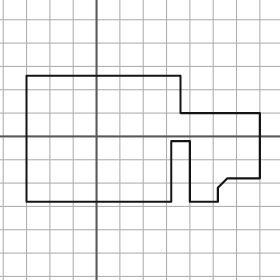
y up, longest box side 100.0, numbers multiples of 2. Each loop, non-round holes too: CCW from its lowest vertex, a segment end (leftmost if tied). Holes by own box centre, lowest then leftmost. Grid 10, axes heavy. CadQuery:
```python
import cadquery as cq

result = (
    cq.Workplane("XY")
    .moveTo(-30.0, -28.0)
    .lineTo(32.0, -28.0)
    .lineTo(32.0, -2.0)
    .lineTo(40.0, -2.0)
    .lineTo(40.0, -28.0)
    .lineTo(52.0, -28.0)
    .lineTo(52.0, -22.0)
    .lineTo(56.0, -18.0)
    .lineTo(70.0, -18.0)
    .lineTo(70.0, 10.0)
    .lineTo(36.0, 10.0)
    .lineTo(36.0, 26.0)
    .lineTo(-30.0, 26.0)
    .close()
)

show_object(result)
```